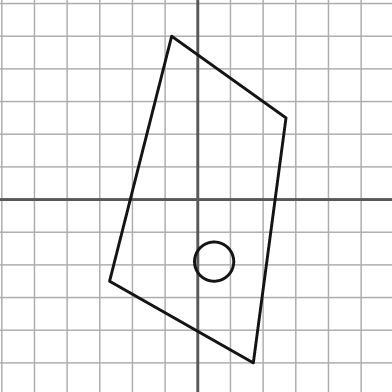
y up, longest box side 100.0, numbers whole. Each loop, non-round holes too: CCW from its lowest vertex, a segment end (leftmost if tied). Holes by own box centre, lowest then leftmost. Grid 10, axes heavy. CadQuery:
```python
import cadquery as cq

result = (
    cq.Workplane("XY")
    .moveTo(17.0, -50.0)
    .lineTo(27.0, 25.0)
    .lineTo(-8.0, 50.0)
    .lineTo(-27.0, -25.0)
    .close()
    .moveTo(5.0, -19.0)
    .circle(6.0)
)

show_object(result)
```